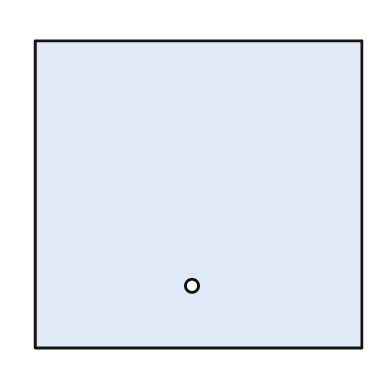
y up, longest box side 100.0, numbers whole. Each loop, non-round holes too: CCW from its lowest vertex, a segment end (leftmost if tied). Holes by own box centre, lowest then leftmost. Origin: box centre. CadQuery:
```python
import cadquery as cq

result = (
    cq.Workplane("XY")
    .moveTo(-50.0, -47.0)
    .lineTo(50.0, -47.0)
    .lineTo(50.0, 47.0)
    .lineTo(-50.0, 47.0)
    .close()
    .moveTo(-2.0, -28.0)
    .circle(2.0)
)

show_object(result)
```